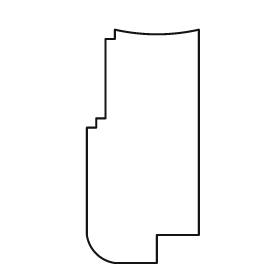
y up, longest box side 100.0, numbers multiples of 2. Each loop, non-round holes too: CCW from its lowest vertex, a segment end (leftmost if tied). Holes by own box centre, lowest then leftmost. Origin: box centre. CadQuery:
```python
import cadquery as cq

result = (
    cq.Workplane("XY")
    .moveTo(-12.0, -50.0)
    .lineTo(6.0, -50.0)
    .lineTo(6.0, -38.0)
    .lineTo(24.0, -38.0)
    .lineTo(24.0, 50.0)
    .threePointArc((6.0, 48.0), (-12.0, 50.0))
    .lineTo(-12.0, 46.0)
    .lineTo(-16.0, 46.0)
    .lineTo(-16.0, 12.0)
    .lineTo(-20.0, 12.0)
    .lineTo(-20.0, 8.0)
    .lineTo(-24.0, 8.0)
    .lineTo(-24.0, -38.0)
    .threePointArc((-20.0, -46.0), (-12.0, -50.0))
    .close()
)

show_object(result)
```